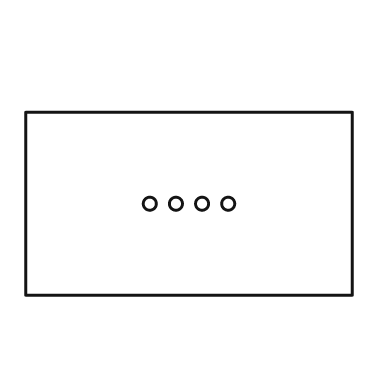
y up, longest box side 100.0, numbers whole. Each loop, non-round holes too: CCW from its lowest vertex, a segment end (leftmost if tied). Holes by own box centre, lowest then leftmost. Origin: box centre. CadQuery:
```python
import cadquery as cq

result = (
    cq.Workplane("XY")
    .moveTo(-50.0, -28.0)
    .lineTo(50.0, -28.0)
    .lineTo(50.0, 28.0)
    .lineTo(-50.0, 28.0)
    .close()
    .moveTo(-12.0, 0.0)
    .circle(2.0)
    .moveTo(-4.0, 0.0)
    .circle(2.0)
    .moveTo(4.0, 0.0)
    .circle(2.0)
    .moveTo(12.0, 0.0)
    .circle(2.0)
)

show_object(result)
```